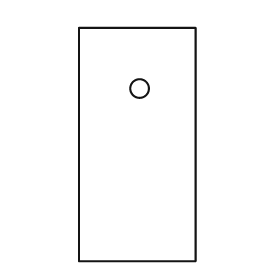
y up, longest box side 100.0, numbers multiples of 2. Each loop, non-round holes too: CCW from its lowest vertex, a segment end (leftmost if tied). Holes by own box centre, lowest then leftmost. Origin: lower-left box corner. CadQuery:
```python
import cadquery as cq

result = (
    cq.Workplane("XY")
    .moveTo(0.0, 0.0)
    .lineTo(50.0, 0.0)
    .lineTo(50.0, 100.0)
    .lineTo(0.0, 100.0)
    .close()
    .moveTo(26.0, 74.0)
    .circle(4.0)
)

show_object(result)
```